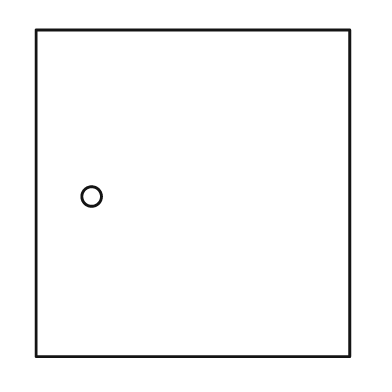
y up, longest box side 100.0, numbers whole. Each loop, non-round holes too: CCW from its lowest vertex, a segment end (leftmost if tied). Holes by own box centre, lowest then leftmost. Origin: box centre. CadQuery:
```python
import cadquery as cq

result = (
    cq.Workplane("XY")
    .moveTo(-48.0, -50.0)
    .lineTo(48.0, -50.0)
    .lineTo(48.0, 50.0)
    .lineTo(-48.0, 50.0)
    .close()
    .moveTo(-31.0, -1.0)
    .circle(3.0)
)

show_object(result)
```